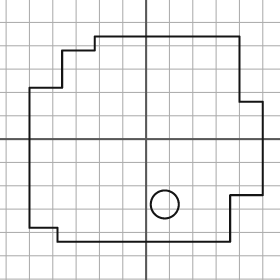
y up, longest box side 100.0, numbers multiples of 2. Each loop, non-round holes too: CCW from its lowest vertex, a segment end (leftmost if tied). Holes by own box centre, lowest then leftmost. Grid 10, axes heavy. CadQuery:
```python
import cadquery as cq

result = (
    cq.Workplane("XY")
    .moveTo(-38.0, -44.0)
    .lineTo(36.0, -44.0)
    .lineTo(36.0, -24.0)
    .lineTo(50.0, -24.0)
    .lineTo(50.0, 16.0)
    .lineTo(40.0, 16.0)
    .lineTo(40.0, 44.0)
    .lineTo(-22.0, 44.0)
    .lineTo(-22.0, 38.0)
    .lineTo(-36.0, 38.0)
    .lineTo(-36.0, 22.0)
    .lineTo(-50.0, 22.0)
    .lineTo(-50.0, -38.0)
    .lineTo(-38.0, -38.0)
    .close()
    .moveTo(8.0, -28.0)
    .circle(6.0)
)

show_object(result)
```